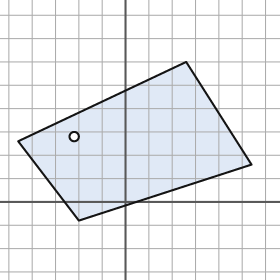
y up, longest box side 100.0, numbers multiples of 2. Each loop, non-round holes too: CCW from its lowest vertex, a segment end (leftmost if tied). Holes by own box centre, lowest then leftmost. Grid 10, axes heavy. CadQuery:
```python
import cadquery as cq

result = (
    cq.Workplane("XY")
    .moveTo(-20.0, -8.0)
    .lineTo(54.0, 16.0)
    .lineTo(26.0, 60.0)
    .lineTo(-46.0, 26.0)
    .close()
    .moveTo(-22.0, 28.0)
    .circle(2.0)
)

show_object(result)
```